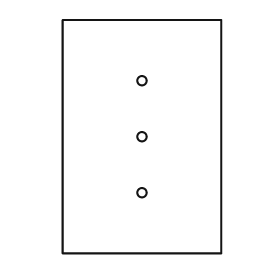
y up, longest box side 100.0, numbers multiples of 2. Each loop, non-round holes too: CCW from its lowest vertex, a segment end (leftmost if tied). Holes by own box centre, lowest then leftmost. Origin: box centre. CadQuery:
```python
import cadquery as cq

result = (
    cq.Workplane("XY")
    .moveTo(-34.0, -50.0)
    .lineTo(34.0, -50.0)
    .lineTo(34.0, 50.0)
    .lineTo(-34.0, 50.0)
    .close()
    .moveTo(0.0, -24.0)
    .circle(2.0)
    .moveTo(0.0, 0.0)
    .circle(2.0)
    .moveTo(0.0, 24.0)
    .circle(2.0)
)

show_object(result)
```